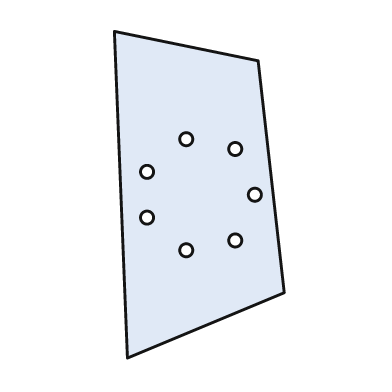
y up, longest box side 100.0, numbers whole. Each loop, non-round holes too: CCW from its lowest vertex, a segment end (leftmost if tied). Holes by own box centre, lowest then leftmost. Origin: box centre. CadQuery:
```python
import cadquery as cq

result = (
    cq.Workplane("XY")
    .moveTo(-22.0, -50.0)
    .lineTo(26.0, -30.0)
    .lineTo(18.0, 41.0)
    .lineTo(-26.0, 50.0)
    .close()
    .moveTo(-4.0, -17.0)
    .circle(2.0)
    .moveTo(11.0, -14.0)
    .circle(2.0)
    .moveTo(-16.0, -7.0)
    .circle(2.0)
    .moveTo(17.0, 0.0)
    .circle(2.0)
    .moveTo(-16.0, 7.0)
    .circle(2.0)
    .moveTo(11.0, 14.0)
    .circle(2.0)
    .moveTo(-4.0, 17.0)
    .circle(2.0)
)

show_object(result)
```